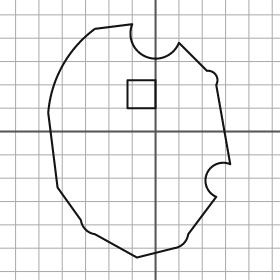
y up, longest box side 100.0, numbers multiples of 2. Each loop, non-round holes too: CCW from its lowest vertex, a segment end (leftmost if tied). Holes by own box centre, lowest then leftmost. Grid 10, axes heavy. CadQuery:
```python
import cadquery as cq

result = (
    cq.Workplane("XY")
    .moveTo(-8.0, -54.0)
    .lineTo(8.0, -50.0)
    .threePointArc((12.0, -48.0), (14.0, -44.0))
    .lineTo(26.0, -28.0)
    .threePointArc((22.0, -18.0), (32.0, -14.0))
    .lineTo(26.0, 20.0)
    .threePointArc((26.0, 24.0), (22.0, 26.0))
    .lineTo(10.0, 38.0)
    .threePointArc((-4.0, 32.0), (-10.0, 46.0))
    .lineTo(-26.0, 44.0)
    .threePointArc((-40.0, 28.0), (-46.0, 8.0))
    .lineTo(-42.0, -24.0)
    .lineTo(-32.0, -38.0)
    .threePointArc((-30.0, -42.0), (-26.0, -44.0))
    .close()
    .moveTo(-12.0, 10.0)
    .lineTo(0.0, 10.0)
    .lineTo(0.0, 22.0)
    .lineTo(-12.0, 22.0)
    .close()
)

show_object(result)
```